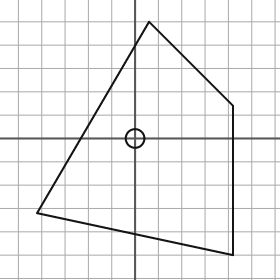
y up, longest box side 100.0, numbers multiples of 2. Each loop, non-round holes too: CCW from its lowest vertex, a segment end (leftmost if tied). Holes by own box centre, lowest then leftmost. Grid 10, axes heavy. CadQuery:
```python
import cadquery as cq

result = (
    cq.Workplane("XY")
    .moveTo(42.0, -50.0)
    .lineTo(42.0, 14.0)
    .lineTo(6.0, 50.0)
    .lineTo(-42.0, -32.0)
    .close()
    .moveTo(0.0, 0.0)
    .circle(4.0)
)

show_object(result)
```